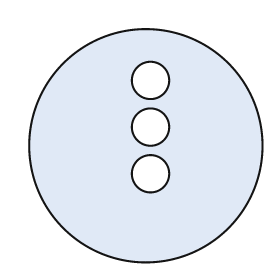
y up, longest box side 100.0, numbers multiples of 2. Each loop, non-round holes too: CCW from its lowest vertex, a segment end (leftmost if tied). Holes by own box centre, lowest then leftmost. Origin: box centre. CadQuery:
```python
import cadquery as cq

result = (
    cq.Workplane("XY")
    .moveTo(0.0, 0.0)
    .circle(50.0)
    .moveTo(2.0, -12.0)
    .circle(8.0)
    .moveTo(2.0, 8.0)
    .circle(8.0)
    .moveTo(2.0, 28.0)
    .circle(8.0)
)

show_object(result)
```